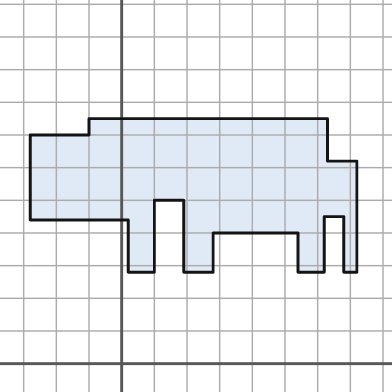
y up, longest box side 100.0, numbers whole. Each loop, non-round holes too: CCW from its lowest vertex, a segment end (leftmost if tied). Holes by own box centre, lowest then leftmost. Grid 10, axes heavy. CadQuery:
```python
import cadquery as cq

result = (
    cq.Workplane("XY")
    .moveTo(2.0, 28.0)
    .lineTo(10.0, 28.0)
    .lineTo(10.0, 50.0)
    .lineTo(19.0, 50.0)
    .lineTo(19.0, 28.0)
    .lineTo(28.0, 28.0)
    .lineTo(28.0, 40.0)
    .lineTo(54.0, 40.0)
    .lineTo(54.0, 28.0)
    .lineTo(62.0, 28.0)
    .lineTo(62.0, 45.0)
    .lineTo(68.0, 45.0)
    .lineTo(68.0, 28.0)
    .lineTo(72.0, 28.0)
    .lineTo(72.0, 62.0)
    .lineTo(63.0, 62.0)
    .lineTo(63.0, 75.0)
    .lineTo(-10.0, 75.0)
    .lineTo(-10.0, 70.0)
    .lineTo(-28.0, 70.0)
    .lineTo(-28.0, 44.0)
    .lineTo(2.0, 44.0)
    .close()
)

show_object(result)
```